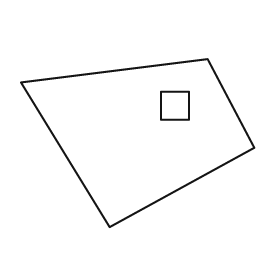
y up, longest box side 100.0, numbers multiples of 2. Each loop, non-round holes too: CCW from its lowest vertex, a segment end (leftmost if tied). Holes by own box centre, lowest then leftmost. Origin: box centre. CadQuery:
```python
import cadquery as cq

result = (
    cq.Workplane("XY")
    .moveTo(-12.0, -36.0)
    .lineTo(50.0, -2.0)
    .lineTo(30.0, 36.0)
    .lineTo(-50.0, 26.0)
    .close()
    .moveTo(10.0, 10.0)
    .lineTo(22.0, 10.0)
    .lineTo(22.0, 22.0)
    .lineTo(10.0, 22.0)
    .close()
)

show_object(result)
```